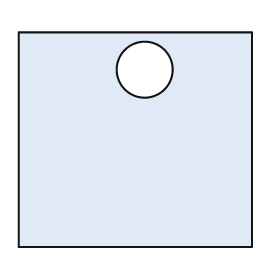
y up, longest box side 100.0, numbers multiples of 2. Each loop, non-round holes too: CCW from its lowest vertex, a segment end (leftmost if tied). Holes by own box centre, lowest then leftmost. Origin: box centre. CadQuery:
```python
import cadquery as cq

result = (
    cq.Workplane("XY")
    .moveTo(-50.0, -46.0)
    .lineTo(50.0, -46.0)
    .lineTo(50.0, 46.0)
    .lineTo(-50.0, 46.0)
    .close()
    .moveTo(4.0, 30.0)
    .circle(12.0)
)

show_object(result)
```